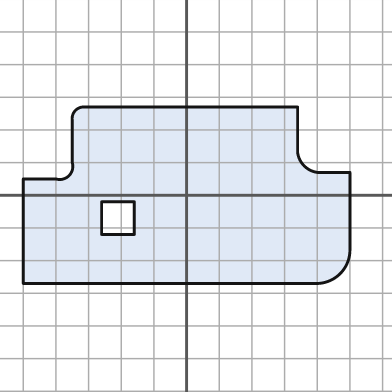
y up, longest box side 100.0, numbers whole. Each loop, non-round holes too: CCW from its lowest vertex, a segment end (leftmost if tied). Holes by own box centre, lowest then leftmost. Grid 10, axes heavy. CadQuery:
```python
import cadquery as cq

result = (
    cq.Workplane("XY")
    .moveTo(-50.0, -27.0)
    .lineTo(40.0, -27.0)
    .threePointArc((47.0, -24.0), (50.0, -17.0))
    .lineTo(50.0, 7.0)
    .lineTo(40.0, 7.0)
    .threePointArc((36.0, 9.0), (34.0, 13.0))
    .lineTo(34.0, 27.0)
    .lineTo(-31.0, 27.0)
    .threePointArc((-34.0, 26.0), (-35.0, 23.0))
    .lineTo(-35.0, 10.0)
    .threePointArc((-36.0, 6.0), (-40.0, 5.0))
    .lineTo(-50.0, 5.0)
    .close()
    .moveTo(-26.0, -12.0)
    .lineTo(-16.0, -12.0)
    .lineTo(-16.0, -2.0)
    .lineTo(-26.0, -2.0)
    .close()
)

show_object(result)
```